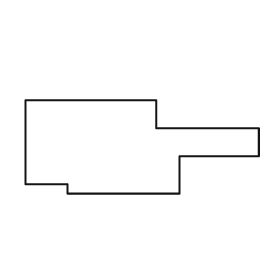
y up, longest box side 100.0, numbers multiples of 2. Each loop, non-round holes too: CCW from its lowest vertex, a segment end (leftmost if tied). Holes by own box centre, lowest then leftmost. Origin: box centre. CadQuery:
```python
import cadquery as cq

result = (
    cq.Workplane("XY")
    .moveTo(-32.0, -20.0)
    .lineTo(16.0, -20.0)
    .lineTo(16.0, -4.0)
    .lineTo(50.0, -4.0)
    .lineTo(50.0, 8.0)
    .lineTo(6.0, 8.0)
    .lineTo(6.0, 20.0)
    .lineTo(-50.0, 20.0)
    .lineTo(-50.0, -16.0)
    .lineTo(-32.0, -16.0)
    .close()
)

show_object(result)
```